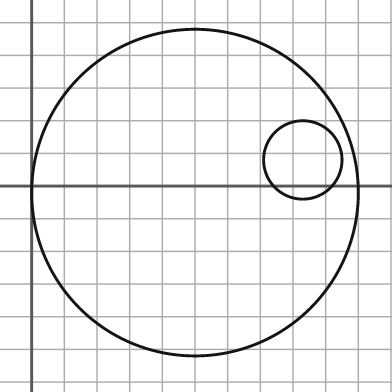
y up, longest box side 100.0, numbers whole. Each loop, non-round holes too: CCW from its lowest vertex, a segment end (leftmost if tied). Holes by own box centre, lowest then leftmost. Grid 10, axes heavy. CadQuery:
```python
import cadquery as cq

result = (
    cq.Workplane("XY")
    .moveTo(50.0, -2.0)
    .circle(50.0)
    .moveTo(83.0, 8.0)
    .circle(12.0)
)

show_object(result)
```